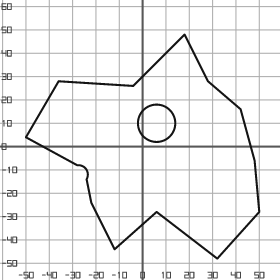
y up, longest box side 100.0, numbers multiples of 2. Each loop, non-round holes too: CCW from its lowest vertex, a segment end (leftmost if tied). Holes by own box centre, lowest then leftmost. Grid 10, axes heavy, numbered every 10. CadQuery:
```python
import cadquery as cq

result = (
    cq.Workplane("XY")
    .moveTo(32.0, -48.0)
    .lineTo(50.0, -28.0)
    .lineTo(48.0, -6.0)
    .lineTo(42.0, 16.0)
    .lineTo(28.0, 28.0)
    .lineTo(18.0, 48.0)
    .lineTo(-4.0, 26.0)
    .lineTo(-36.0, 28.0)
    .lineTo(-50.0, 4.0)
    .lineTo(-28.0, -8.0)
    .threePointArc((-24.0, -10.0), (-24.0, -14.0))
    .lineTo(-22.0, -24.0)
    .lineTo(-12.0, -44.0)
    .lineTo(6.0, -28.0)
    .close()
    .moveTo(6.0, 10.0)
    .circle(8.0)
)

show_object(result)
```